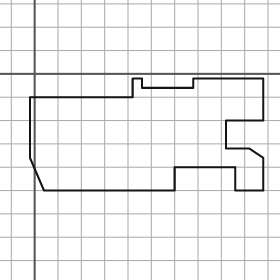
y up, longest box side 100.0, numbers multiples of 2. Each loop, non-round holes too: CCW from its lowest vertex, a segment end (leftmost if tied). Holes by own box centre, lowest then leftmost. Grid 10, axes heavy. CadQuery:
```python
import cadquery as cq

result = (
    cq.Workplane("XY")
    .moveTo(4.0, -50.0)
    .lineTo(60.0, -50.0)
    .lineTo(60.0, -40.0)
    .lineTo(86.0, -40.0)
    .lineTo(86.0, -50.0)
    .lineTo(98.0, -50.0)
    .lineTo(98.0, -36.0)
    .lineTo(92.0, -32.0)
    .lineTo(82.0, -32.0)
    .lineTo(82.0, -20.0)
    .lineTo(98.0, -20.0)
    .lineTo(98.0, -2.0)
    .lineTo(68.0, -2.0)
    .lineTo(68.0, -6.0)
    .lineTo(46.0, -6.0)
    .lineTo(46.0, -2.0)
    .lineTo(42.0, -2.0)
    .lineTo(42.0, -10.0)
    .lineTo(-2.0, -10.0)
    .lineTo(-2.0, -36.0)
    .close()
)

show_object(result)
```